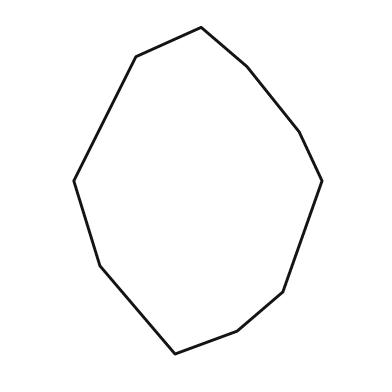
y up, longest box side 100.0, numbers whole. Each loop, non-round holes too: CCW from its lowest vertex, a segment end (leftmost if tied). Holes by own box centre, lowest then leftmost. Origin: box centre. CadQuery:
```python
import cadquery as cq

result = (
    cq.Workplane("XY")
    .moveTo(-7.0, -50.0)
    .lineTo(12.0, -43.0)
    .lineTo(26.0, -31.0)
    .lineTo(38.0, 3.0)
    .lineTo(31.0, 18.0)
    .lineTo(15.0, 38.0)
    .lineTo(1.0, 50.0)
    .lineTo(-19.0, 41.0)
    .lineTo(-38.0, 3.0)
    .lineTo(-30.0, -23.0)
    .close()
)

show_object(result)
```